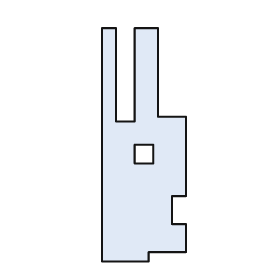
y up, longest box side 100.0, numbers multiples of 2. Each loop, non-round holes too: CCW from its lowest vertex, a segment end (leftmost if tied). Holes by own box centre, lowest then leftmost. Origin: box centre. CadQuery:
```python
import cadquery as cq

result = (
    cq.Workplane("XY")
    .moveTo(-18.0, -50.0)
    .lineTo(2.0, -50.0)
    .lineTo(2.0, -46.0)
    .lineTo(18.0, -46.0)
    .lineTo(18.0, -34.0)
    .lineTo(12.0, -34.0)
    .lineTo(12.0, -22.0)
    .lineTo(18.0, -22.0)
    .lineTo(18.0, 12.0)
    .lineTo(6.0, 12.0)
    .lineTo(6.0, 50.0)
    .lineTo(-4.0, 50.0)
    .lineTo(-4.0, 10.0)
    .lineTo(-12.0, 10.0)
    .lineTo(-12.0, 50.0)
    .lineTo(-18.0, 50.0)
    .close()
    .moveTo(-4.0, -8.0)
    .lineTo(4.0, -8.0)
    .lineTo(4.0, 0.0)
    .lineTo(-4.0, 0.0)
    .close()
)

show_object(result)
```